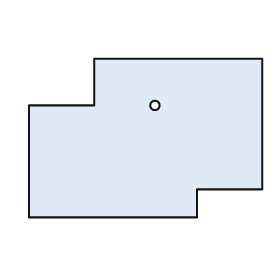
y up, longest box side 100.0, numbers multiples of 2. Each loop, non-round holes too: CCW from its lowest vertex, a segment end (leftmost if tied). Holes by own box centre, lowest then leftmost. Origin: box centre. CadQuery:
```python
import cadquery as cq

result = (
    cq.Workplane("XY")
    .moveTo(-50.0, -34.0)
    .lineTo(22.0, -34.0)
    .lineTo(22.0, -22.0)
    .lineTo(50.0, -22.0)
    .lineTo(50.0, 34.0)
    .lineTo(-22.0, 34.0)
    .lineTo(-22.0, 14.0)
    .lineTo(-50.0, 14.0)
    .close()
    .moveTo(4.0, 14.0)
    .circle(2.0)
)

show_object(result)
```